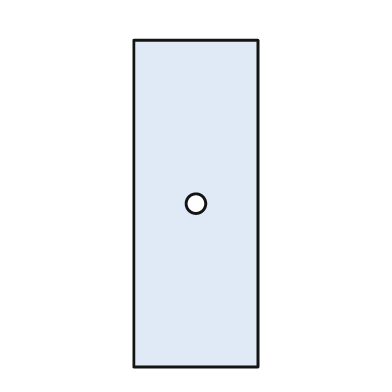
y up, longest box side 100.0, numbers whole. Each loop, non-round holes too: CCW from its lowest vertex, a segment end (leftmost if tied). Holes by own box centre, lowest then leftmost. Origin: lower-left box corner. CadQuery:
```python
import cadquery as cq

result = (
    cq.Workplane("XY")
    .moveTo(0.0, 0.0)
    .lineTo(38.0, 0.0)
    .lineTo(38.0, 100.0)
    .lineTo(0.0, 100.0)
    .close()
    .moveTo(19.0, 50.0)
    .circle(3.0)
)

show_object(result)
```